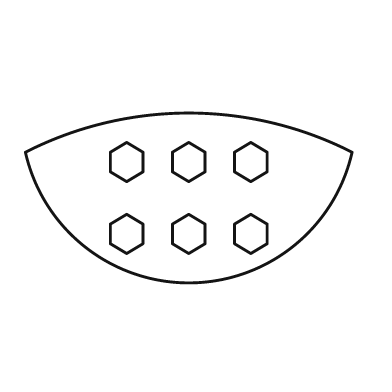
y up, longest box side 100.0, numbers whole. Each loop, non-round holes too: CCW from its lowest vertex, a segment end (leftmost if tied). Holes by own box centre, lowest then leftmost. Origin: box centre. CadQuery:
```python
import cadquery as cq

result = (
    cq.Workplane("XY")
    .moveTo(-50.0, 14.0)
    .threePointArc((0.0, -26.0), (50.0, 14.0))
    .threePointArc((0.0, 26.0), (-50.0, 14.0))
    .close()
    .moveTo(-19.0, -17.0)
    .lineTo(-14.0, -14.0)
    .lineTo(-14.0, -8.0)
    .lineTo(-19.0, -5.0)
    .lineTo(-24.0, -8.0)
    .lineTo(-24.0, -14.0)
    .close()
    .moveTo(0.0, -17.0)
    .lineTo(5.0, -14.0)
    .lineTo(5.0, -8.0)
    .lineTo(0.0, -5.0)
    .lineTo(-5.0, -8.0)
    .lineTo(-5.0, -14.0)
    .close()
    .moveTo(19.0, -17.0)
    .lineTo(24.0, -14.0)
    .lineTo(24.0, -8.0)
    .lineTo(19.0, -5.0)
    .lineTo(14.0, -8.0)
    .lineTo(14.0, -14.0)
    .close()
    .moveTo(-19.0, 5.0)
    .lineTo(-14.0, 8.0)
    .lineTo(-14.0, 14.0)
    .lineTo(-19.0, 17.0)
    .lineTo(-24.0, 14.0)
    .lineTo(-24.0, 8.0)
    .close()
    .moveTo(0.0, 5.0)
    .lineTo(5.0, 8.0)
    .lineTo(5.0, 14.0)
    .lineTo(0.0, 17.0)
    .lineTo(-5.0, 14.0)
    .lineTo(-5.0, 8.0)
    .close()
    .moveTo(19.0, 5.0)
    .lineTo(24.0, 8.0)
    .lineTo(24.0, 14.0)
    .lineTo(19.0, 17.0)
    .lineTo(14.0, 14.0)
    .lineTo(14.0, 8.0)
    .close()
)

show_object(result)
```